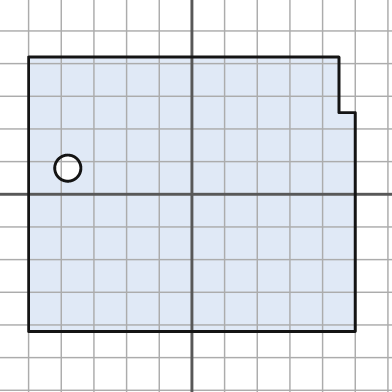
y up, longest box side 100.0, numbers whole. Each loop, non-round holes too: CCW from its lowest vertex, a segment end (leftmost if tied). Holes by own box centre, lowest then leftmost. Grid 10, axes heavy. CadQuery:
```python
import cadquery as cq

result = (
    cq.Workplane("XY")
    .moveTo(-50.0, -42.0)
    .lineTo(50.0, -42.0)
    .lineTo(50.0, 25.0)
    .lineTo(45.0, 25.0)
    .lineTo(45.0, 42.0)
    .lineTo(-50.0, 42.0)
    .close()
    .moveTo(-38.0, 8.0)
    .circle(4.0)
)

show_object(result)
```